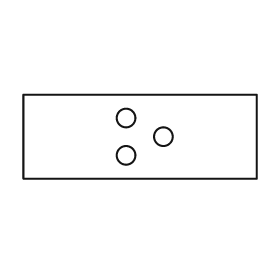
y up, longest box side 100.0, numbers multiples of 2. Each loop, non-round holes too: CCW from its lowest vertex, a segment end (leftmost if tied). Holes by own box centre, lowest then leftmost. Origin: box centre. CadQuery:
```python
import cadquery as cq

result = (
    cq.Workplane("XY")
    .moveTo(-50.0, -18.0)
    .lineTo(50.0, -18.0)
    .lineTo(50.0, 18.0)
    .lineTo(-50.0, 18.0)
    .close()
    .moveTo(-6.0, -8.0)
    .circle(4.0)
    .moveTo(10.0, 0.0)
    .circle(4.0)
    .moveTo(-6.0, 8.0)
    .circle(4.0)
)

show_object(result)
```